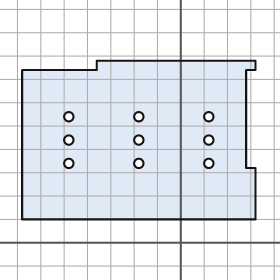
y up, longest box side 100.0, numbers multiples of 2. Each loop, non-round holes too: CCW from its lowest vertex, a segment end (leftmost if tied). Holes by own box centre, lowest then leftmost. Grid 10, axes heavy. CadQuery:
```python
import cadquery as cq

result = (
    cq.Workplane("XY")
    .moveTo(-68.0, 10.0)
    .lineTo(32.0, 10.0)
    .lineTo(32.0, 32.0)
    .lineTo(28.0, 32.0)
    .lineTo(28.0, 74.0)
    .lineTo(32.0, 74.0)
    .lineTo(32.0, 78.0)
    .lineTo(-36.0, 78.0)
    .lineTo(-36.0, 74.0)
    .lineTo(-68.0, 74.0)
    .close()
    .moveTo(-48.0, 34.0)
    .circle(2.0)
    .moveTo(-18.0, 34.0)
    .circle(2.0)
    .moveTo(12.0, 34.0)
    .circle(2.0)
    .moveTo(-48.0, 44.0)
    .circle(2.0)
    .moveTo(-18.0, 44.0)
    .circle(2.0)
    .moveTo(12.0, 44.0)
    .circle(2.0)
    .moveTo(-48.0, 54.0)
    .circle(2.0)
    .moveTo(-18.0, 54.0)
    .circle(2.0)
    .moveTo(12.0, 54.0)
    .circle(2.0)
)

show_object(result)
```